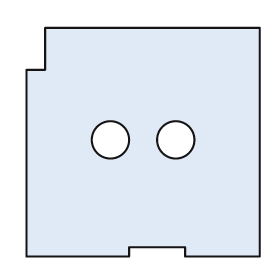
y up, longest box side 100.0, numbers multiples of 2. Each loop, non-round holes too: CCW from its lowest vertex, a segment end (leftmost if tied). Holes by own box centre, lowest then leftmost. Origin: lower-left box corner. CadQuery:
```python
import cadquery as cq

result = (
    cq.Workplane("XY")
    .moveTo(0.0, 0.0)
    .lineTo(44.0, 0.0)
    .lineTo(44.0, 4.0)
    .lineTo(68.0, 4.0)
    .lineTo(68.0, 0.0)
    .lineTo(100.0, 0.0)
    .lineTo(100.0, 98.0)
    .lineTo(8.0, 98.0)
    .lineTo(8.0, 80.0)
    .lineTo(0.0, 80.0)
    .close()
    .moveTo(36.0, 50.0)
    .circle(8.0)
    .moveTo(64.0, 50.0)
    .circle(8.0)
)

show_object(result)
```